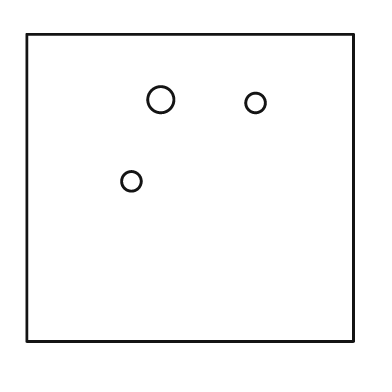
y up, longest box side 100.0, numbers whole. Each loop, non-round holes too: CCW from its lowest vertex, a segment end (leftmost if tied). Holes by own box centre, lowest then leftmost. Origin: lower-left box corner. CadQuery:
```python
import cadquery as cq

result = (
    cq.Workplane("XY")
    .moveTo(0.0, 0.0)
    .lineTo(100.0, 0.0)
    .lineTo(100.0, 94.0)
    .lineTo(0.0, 94.0)
    .close()
    .moveTo(32.0, 49.0)
    .circle(3.0)
    .moveTo(70.0, 73.0)
    .circle(3.0)
    .moveTo(41.0, 74.0)
    .circle(4.0)
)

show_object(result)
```